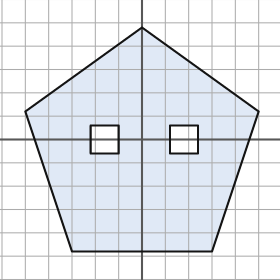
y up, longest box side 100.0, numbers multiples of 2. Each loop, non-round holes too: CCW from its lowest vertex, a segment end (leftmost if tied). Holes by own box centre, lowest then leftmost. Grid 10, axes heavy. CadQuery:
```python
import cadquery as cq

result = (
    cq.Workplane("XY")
    .moveTo(-30.0, -48.0)
    .lineTo(30.0, -48.0)
    .lineTo(50.0, 12.0)
    .lineTo(0.0, 48.0)
    .lineTo(-50.0, 12.0)
    .close()
    .moveTo(-22.0, -6.0)
    .lineTo(-10.0, -6.0)
    .lineTo(-10.0, 6.0)
    .lineTo(-22.0, 6.0)
    .close()
    .moveTo(12.0, -6.0)
    .lineTo(24.0, -6.0)
    .lineTo(24.0, 6.0)
    .lineTo(12.0, 6.0)
    .close()
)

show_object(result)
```